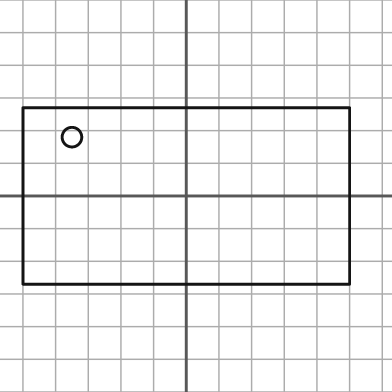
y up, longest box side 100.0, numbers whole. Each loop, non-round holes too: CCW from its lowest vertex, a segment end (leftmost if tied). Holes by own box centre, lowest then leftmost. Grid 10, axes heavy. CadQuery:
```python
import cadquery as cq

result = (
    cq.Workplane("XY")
    .moveTo(-50.0, -27.0)
    .lineTo(50.0, -27.0)
    .lineTo(50.0, 27.0)
    .lineTo(-50.0, 27.0)
    .close()
    .moveTo(-35.0, 18.0)
    .circle(3.0)
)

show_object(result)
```